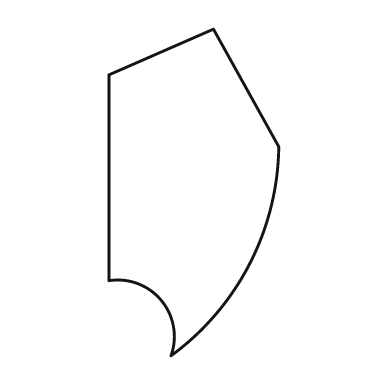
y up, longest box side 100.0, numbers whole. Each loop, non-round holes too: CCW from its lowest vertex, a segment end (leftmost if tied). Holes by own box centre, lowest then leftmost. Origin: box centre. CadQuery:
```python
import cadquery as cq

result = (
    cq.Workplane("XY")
    .moveTo(-7.0, -50.0)
    .threePointArc((17.0, -22.0), (26.0, 14.0))
    .lineTo(6.0, 50.0)
    .lineTo(-26.0, 36.0)
    .lineTo(-26.0, -27.0)
    .threePointArc((-10.0, -33.0), (-7.0, -50.0))
    .close()
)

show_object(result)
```